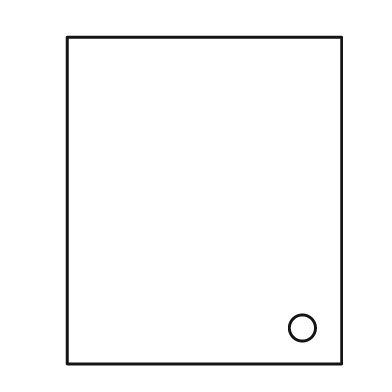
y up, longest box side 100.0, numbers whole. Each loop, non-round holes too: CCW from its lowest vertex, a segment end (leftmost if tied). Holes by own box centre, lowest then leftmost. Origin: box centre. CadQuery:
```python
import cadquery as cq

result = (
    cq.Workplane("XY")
    .moveTo(-42.0, -50.0)
    .lineTo(42.0, -50.0)
    .lineTo(42.0, 50.0)
    .lineTo(-42.0, 50.0)
    .close()
    .moveTo(30.0, -39.0)
    .circle(4.0)
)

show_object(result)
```